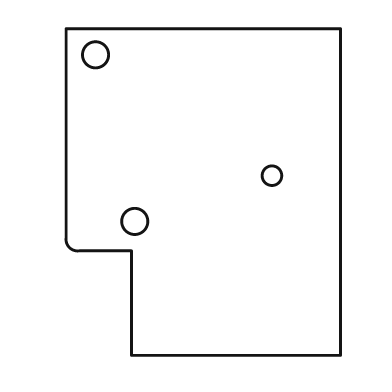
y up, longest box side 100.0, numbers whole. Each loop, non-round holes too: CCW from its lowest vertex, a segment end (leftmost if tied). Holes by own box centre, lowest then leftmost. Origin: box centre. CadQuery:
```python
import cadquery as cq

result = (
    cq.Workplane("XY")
    .moveTo(-22.0, -50.0)
    .lineTo(42.0, -50.0)
    .lineTo(42.0, 50.0)
    .lineTo(-42.0, 50.0)
    .lineTo(-42.0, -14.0)
    .threePointArc((-41.0, -17.0), (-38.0, -18.0))
    .lineTo(-22.0, -18.0)
    .close()
    .moveTo(-21.0, -9.0)
    .circle(4.0)
    .moveTo(21.0, 5.0)
    .circle(3.0)
    .moveTo(-33.0, 42.0)
    .circle(4.0)
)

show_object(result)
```